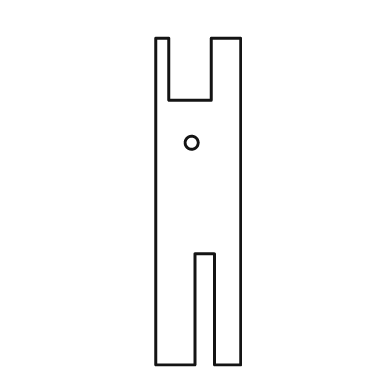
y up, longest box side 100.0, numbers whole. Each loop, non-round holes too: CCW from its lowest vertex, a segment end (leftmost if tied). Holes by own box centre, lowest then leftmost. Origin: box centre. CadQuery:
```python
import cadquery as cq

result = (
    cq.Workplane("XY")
    .moveTo(-13.0, -50.0)
    .lineTo(-1.0, -50.0)
    .lineTo(-1.0, -16.0)
    .lineTo(5.0, -16.0)
    .lineTo(5.0, -50.0)
    .lineTo(13.0, -50.0)
    .lineTo(13.0, 50.0)
    .lineTo(4.0, 50.0)
    .lineTo(4.0, 31.0)
    .lineTo(-9.0, 31.0)
    .lineTo(-9.0, 50.0)
    .lineTo(-13.0, 50.0)
    .close()
    .moveTo(-2.0, 18.0)
    .circle(2.0)
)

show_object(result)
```